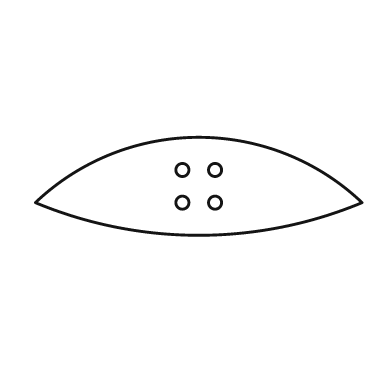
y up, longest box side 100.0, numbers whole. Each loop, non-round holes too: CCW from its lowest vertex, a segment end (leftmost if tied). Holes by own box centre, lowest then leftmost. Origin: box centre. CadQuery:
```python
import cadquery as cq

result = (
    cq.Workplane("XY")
    .moveTo(-50.0, -5.0)
    .threePointArc((0.0, -15.0), (50.0, -5.0))
    .threePointArc((0.0, 15.0), (-50.0, -5.0))
    .close()
    .moveTo(-5.0, -5.0)
    .circle(2.0)
    .moveTo(5.0, -5.0)
    .circle(2.0)
    .moveTo(-5.0, 5.0)
    .circle(2.0)
    .moveTo(5.0, 5.0)
    .circle(2.0)
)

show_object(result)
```